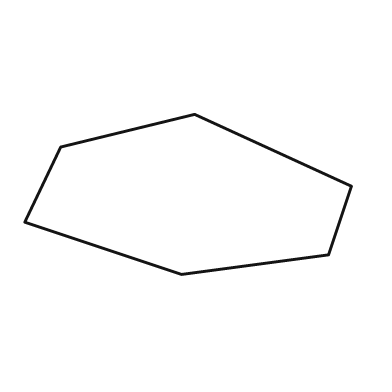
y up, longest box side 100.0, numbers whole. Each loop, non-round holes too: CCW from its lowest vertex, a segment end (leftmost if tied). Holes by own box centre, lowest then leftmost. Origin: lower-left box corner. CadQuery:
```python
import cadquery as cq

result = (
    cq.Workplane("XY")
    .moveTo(48.0, 0.0)
    .lineTo(93.0, 6.0)
    .lineTo(100.0, 27.0)
    .lineTo(52.0, 49.0)
    .lineTo(11.0, 39.0)
    .lineTo(0.0, 16.0)
    .close()
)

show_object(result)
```